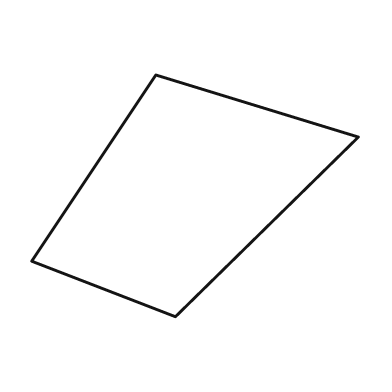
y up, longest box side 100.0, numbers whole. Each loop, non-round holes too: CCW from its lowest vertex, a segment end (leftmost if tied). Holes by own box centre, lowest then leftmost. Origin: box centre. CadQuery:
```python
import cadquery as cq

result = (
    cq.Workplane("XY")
    .moveTo(-6.0, -37.0)
    .lineTo(50.0, 18.0)
    .lineTo(-12.0, 37.0)
    .lineTo(-50.0, -20.0)
    .close()
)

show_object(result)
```